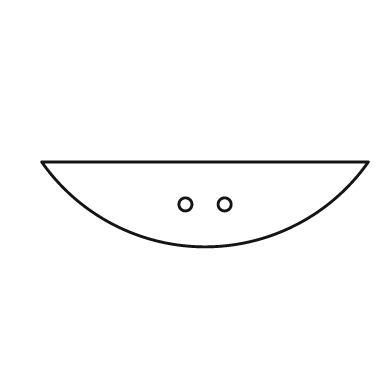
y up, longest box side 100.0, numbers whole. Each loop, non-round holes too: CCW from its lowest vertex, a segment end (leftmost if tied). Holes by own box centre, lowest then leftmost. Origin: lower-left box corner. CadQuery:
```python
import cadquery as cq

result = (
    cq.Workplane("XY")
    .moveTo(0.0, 26.0)
    .threePointArc((50.0, 0.0), (100.0, 26.0))
    .close()
    .moveTo(44.0, 13.0)
    .circle(2.0)
    .moveTo(56.0, 13.0)
    .circle(2.0)
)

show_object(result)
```